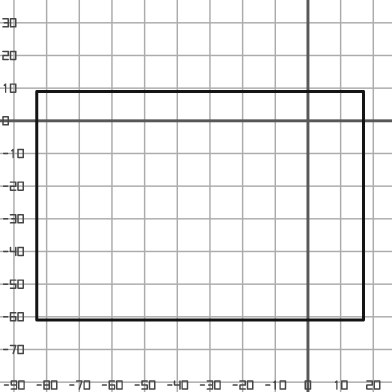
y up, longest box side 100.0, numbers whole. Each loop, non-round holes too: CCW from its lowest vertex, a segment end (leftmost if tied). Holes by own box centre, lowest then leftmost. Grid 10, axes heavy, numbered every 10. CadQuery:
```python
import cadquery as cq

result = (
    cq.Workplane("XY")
    .moveTo(-83.0, -61.0)
    .lineTo(17.0, -61.0)
    .lineTo(17.0, 9.0)
    .lineTo(-83.0, 9.0)
    .close()
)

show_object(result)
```